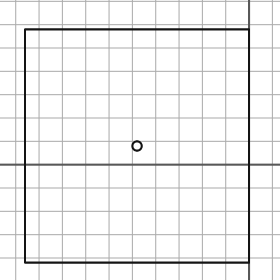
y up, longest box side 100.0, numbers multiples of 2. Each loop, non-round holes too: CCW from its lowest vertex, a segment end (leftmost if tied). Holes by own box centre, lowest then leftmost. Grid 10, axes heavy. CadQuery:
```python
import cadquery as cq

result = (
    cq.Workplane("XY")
    .moveTo(-96.0, -42.0)
    .lineTo(0.0, -42.0)
    .lineTo(0.0, 58.0)
    .lineTo(-96.0, 58.0)
    .close()
    .moveTo(-48.0, 8.0)
    .circle(2.0)
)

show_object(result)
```